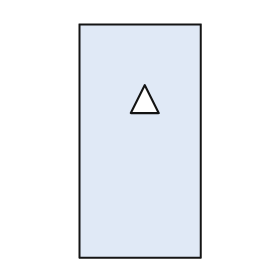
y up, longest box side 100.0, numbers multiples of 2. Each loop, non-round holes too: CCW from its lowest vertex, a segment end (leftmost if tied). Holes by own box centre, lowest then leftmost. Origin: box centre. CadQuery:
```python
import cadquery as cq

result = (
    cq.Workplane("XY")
    .moveTo(-26.0, -50.0)
    .lineTo(26.0, -50.0)
    .lineTo(26.0, 50.0)
    .lineTo(-26.0, 50.0)
    .close()
    .moveTo(-4.0, 12.0)
    .lineTo(8.0, 12.0)
    .lineTo(2.0, 24.0)
    .close()
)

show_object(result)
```